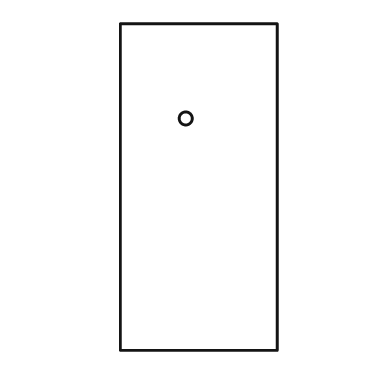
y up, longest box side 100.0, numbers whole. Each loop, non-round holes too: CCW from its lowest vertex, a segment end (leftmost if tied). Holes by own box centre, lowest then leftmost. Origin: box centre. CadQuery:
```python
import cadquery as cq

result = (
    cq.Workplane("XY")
    .moveTo(-24.0, -50.0)
    .lineTo(24.0, -50.0)
    .lineTo(24.0, 50.0)
    .lineTo(-24.0, 50.0)
    .close()
    .moveTo(-4.0, 21.0)
    .circle(2.0)
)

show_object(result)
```